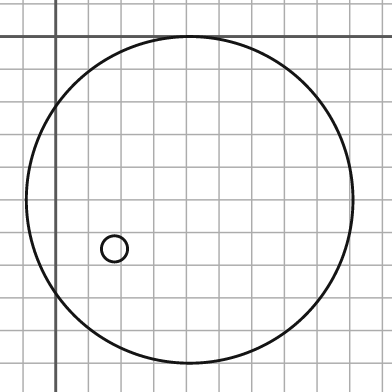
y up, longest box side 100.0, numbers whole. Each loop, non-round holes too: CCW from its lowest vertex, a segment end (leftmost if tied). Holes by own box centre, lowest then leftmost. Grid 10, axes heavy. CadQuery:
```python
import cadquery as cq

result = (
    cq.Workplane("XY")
    .moveTo(41.0, -50.0)
    .circle(50.0)
    .moveTo(18.0, -65.0)
    .circle(4.0)
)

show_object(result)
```